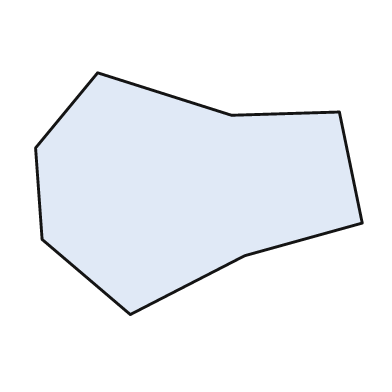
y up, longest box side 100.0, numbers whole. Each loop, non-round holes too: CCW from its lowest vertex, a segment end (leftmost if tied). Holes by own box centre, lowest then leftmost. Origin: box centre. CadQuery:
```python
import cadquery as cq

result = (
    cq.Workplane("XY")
    .moveTo(-21.0, -37.0)
    .lineTo(14.0, -19.0)
    .lineTo(50.0, -9.0)
    .lineTo(43.0, 25.0)
    .lineTo(10.0, 24.0)
    .lineTo(-31.0, 37.0)
    .lineTo(-50.0, 14.0)
    .lineTo(-48.0, -14.0)
    .close()
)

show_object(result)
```